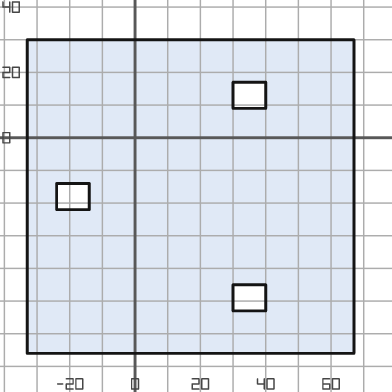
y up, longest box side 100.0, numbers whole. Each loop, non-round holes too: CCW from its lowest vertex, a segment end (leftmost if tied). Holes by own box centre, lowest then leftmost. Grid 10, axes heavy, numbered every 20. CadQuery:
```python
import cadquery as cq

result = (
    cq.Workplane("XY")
    .moveTo(-33.0, -66.0)
    .lineTo(67.0, -66.0)
    .lineTo(67.0, 30.0)
    .lineTo(-33.0, 30.0)
    .close()
    .moveTo(30.0, -53.0)
    .lineTo(40.0, -53.0)
    .lineTo(40.0, -45.0)
    .lineTo(30.0, -45.0)
    .close()
    .moveTo(-24.0, -22.0)
    .lineTo(-14.0, -22.0)
    .lineTo(-14.0, -14.0)
    .lineTo(-24.0, -14.0)
    .close()
    .moveTo(30.0, 9.0)
    .lineTo(40.0, 9.0)
    .lineTo(40.0, 17.0)
    .lineTo(30.0, 17.0)
    .close()
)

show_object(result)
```